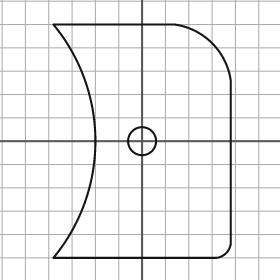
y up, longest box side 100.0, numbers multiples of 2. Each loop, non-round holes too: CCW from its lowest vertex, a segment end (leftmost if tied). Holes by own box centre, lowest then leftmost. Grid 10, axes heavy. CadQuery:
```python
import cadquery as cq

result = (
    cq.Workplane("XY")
    .moveTo(-38.0, -50.0)
    .lineTo(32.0, -50.0)
    .threePointArc((36.0, -48.0), (38.0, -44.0))
    .lineTo(38.0, 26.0)
    .threePointArc((30.0, 42.0), (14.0, 50.0))
    .lineTo(-38.0, 50.0)
    .threePointArc((-20.0, 0.0), (-38.0, -50.0))
    .close()
    .moveTo(0.0, 0.0)
    .circle(6.0)
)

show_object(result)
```